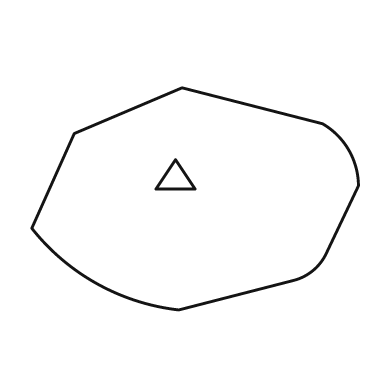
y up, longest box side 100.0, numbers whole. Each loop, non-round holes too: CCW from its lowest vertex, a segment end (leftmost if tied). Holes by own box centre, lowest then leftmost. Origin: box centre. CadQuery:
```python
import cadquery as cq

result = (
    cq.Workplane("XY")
    .moveTo(-5.0, -34.0)
    .lineTo(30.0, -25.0)
    .threePointArc((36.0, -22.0), (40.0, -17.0))
    .lineTo(50.0, 4.0)
    .threePointArc((47.0, 15.0), (39.0, 23.0))
    .lineTo(-4.0, 34.0)
    .lineTo(-37.0, 20.0)
    .lineTo(-50.0, -9.0)
    .threePointArc((-30.0, -26.0), (-5.0, -34.0))
    .close()
    .moveTo(-12.0, 3.0)
    .lineTo(0.0, 3.0)
    .lineTo(-6.0, 12.0)
    .close()
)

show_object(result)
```